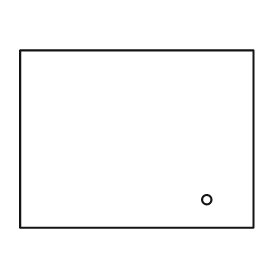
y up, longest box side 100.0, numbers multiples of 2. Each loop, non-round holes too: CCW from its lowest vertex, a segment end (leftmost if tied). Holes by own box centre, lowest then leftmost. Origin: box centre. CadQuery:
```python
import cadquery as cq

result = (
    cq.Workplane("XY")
    .moveTo(-50.0, -38.0)
    .lineTo(50.0, -38.0)
    .lineTo(50.0, 38.0)
    .lineTo(-50.0, 38.0)
    .close()
    .moveTo(30.0, -26.0)
    .circle(2.0)
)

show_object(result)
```